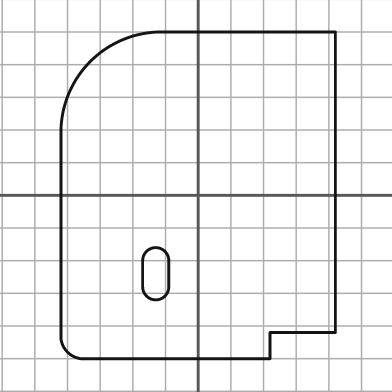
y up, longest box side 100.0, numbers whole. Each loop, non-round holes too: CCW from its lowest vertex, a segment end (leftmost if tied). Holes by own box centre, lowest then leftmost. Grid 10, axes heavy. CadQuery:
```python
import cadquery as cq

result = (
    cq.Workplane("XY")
    .moveTo(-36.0, -50.0)
    .lineTo(22.0, -50.0)
    .lineTo(22.0, -42.0)
    .lineTo(42.0, -42.0)
    .lineTo(42.0, 50.0)
    .lineTo(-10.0, 50.0)
    .threePointArc((-33.0, 41.0), (-42.0, 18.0))
    .lineTo(-42.0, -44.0)
    .threePointArc((-40.0, -48.0), (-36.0, -50.0))
    .close()
    .moveTo(-17.0, -28.0)
    .threePointArc((-13.0, -32.0), (-9.0, -28.0))
    .lineTo(-9.0, -20.0)
    .threePointArc((-13.0, -16.0), (-17.0, -20.0))
    .close()
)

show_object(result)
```